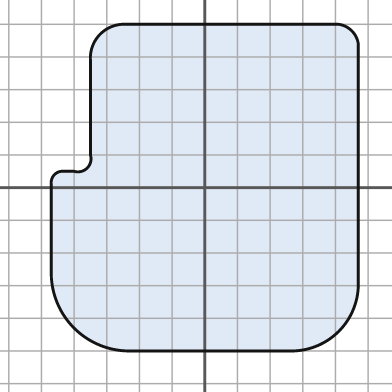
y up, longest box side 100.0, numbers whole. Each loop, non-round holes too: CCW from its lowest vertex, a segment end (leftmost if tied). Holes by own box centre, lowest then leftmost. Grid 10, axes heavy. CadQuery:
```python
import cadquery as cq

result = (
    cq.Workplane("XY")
    .moveTo(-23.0, -50.0)
    .lineTo(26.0, -50.0)
    .threePointArc((41.0, -44.0), (47.0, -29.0))
    .lineTo(47.0, 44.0)
    .threePointArc((45.0, 48.0), (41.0, 50.0))
    .lineTo(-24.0, 50.0)
    .threePointArc((-32.0, 47.0), (-35.0, 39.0))
    .lineTo(-35.0, 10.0)
    .threePointArc((-36.0, 6.0), (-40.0, 5.0))
    .lineTo(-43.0, 5.0)
    .threePointArc((-46.0, 4.0), (-47.0, 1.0))
    .lineTo(-47.0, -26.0)
    .threePointArc((-40.0, -43.0), (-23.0, -50.0))
    .close()
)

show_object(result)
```